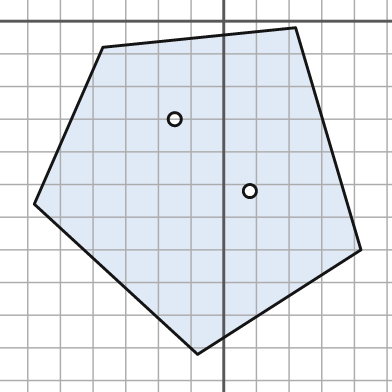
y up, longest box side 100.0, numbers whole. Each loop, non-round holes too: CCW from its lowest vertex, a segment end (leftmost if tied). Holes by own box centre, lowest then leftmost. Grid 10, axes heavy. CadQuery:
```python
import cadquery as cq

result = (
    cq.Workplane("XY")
    .moveTo(-8.0, -102.0)
    .lineTo(42.0, -70.0)
    .lineTo(22.0, -2.0)
    .lineTo(-37.0, -8.0)
    .lineTo(-58.0, -56.0)
    .close()
    .moveTo(8.0, -52.0)
    .circle(2.0)
    .moveTo(-15.0, -30.0)
    .circle(2.0)
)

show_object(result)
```